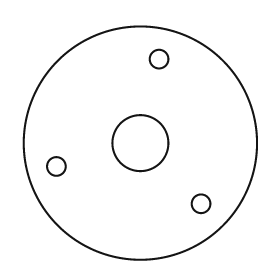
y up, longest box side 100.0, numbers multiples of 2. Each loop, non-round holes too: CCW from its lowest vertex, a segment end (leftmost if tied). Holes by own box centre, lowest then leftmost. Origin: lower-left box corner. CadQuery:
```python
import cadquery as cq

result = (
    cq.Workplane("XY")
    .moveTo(50.0, 50.0)
    .circle(50.0)
    .moveTo(76.0, 24.0)
    .circle(4.0)
    .moveTo(14.0, 40.0)
    .circle(4.0)
    .moveTo(50.0, 50.0)
    .circle(12.0)
    .moveTo(58.0, 86.0)
    .circle(4.0)
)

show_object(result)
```